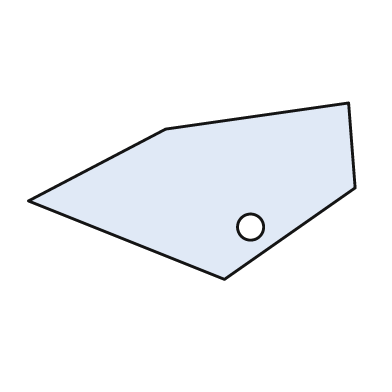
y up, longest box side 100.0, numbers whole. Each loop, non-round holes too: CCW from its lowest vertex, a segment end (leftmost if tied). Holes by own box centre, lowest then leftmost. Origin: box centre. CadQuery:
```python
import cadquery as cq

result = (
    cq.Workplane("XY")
    .moveTo(10.0, -27.0)
    .lineTo(50.0, 1.0)
    .lineTo(48.0, 27.0)
    .lineTo(-8.0, 19.0)
    .lineTo(-50.0, -3.0)
    .close()
    .moveTo(18.0, -11.0)
    .circle(4.0)
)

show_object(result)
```